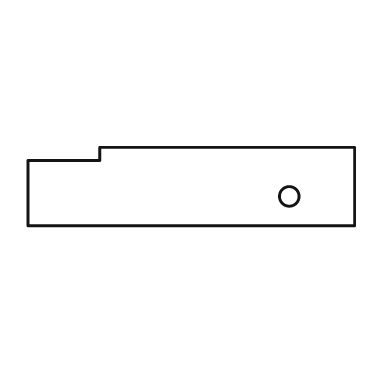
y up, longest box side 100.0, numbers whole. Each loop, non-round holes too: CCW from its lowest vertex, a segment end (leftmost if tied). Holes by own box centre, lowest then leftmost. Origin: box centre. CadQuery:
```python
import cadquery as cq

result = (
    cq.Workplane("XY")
    .moveTo(-50.0, -12.0)
    .lineTo(50.0, -12.0)
    .lineTo(50.0, 12.0)
    .lineTo(-28.0, 12.0)
    .lineTo(-28.0, 8.0)
    .lineTo(-50.0, 8.0)
    .close()
    .moveTo(30.0, -3.0)
    .circle(3.0)
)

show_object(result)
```